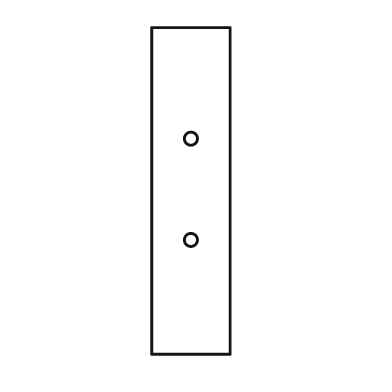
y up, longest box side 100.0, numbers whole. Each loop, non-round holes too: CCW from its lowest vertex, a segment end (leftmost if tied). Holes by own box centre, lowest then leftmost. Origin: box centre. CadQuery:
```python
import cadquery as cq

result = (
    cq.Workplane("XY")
    .moveTo(-12.0, -50.0)
    .lineTo(12.0, -50.0)
    .lineTo(12.0, 50.0)
    .lineTo(-12.0, 50.0)
    .close()
    .moveTo(0.0, -15.0)
    .circle(2.0)
    .moveTo(0.0, 16.0)
    .circle(2.0)
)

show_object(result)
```